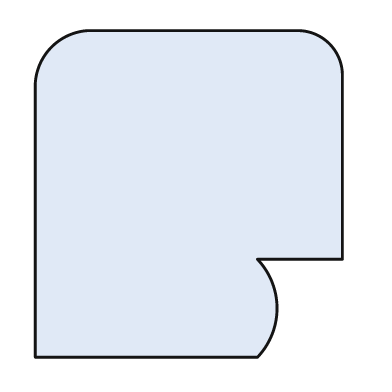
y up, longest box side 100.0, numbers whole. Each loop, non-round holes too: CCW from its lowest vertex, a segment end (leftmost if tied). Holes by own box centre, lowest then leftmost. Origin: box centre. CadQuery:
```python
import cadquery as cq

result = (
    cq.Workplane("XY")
    .moveTo(-47.0, -50.0)
    .lineTo(21.0, -50.0)
    .threePointArc((27.0, -35.0), (21.0, -20.0))
    .lineTo(47.0, -20.0)
    .lineTo(47.0, 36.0)
    .threePointArc((43.0, 46.0), (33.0, 50.0))
    .lineTo(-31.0, 50.0)
    .threePointArc((-42.0, 45.0), (-47.0, 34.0))
    .close()
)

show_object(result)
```